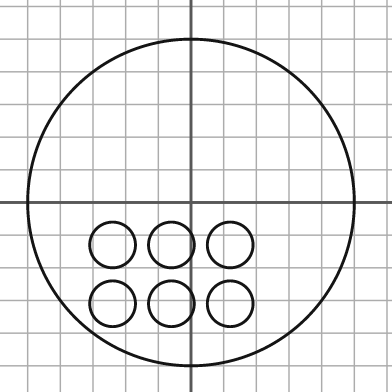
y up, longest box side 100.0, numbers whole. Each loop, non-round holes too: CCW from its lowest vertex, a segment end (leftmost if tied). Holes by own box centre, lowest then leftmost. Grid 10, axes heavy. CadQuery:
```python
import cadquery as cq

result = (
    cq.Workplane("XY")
    .moveTo(0.0, 0.0)
    .circle(50.0)
    .moveTo(-24.0, -31.0)
    .circle(7.0)
    .moveTo(-6.0, -31.0)
    .circle(7.0)
    .moveTo(12.0, -31.0)
    .circle(7.0)
    .moveTo(-24.0, -13.0)
    .circle(7.0)
    .moveTo(-6.0, -13.0)
    .circle(7.0)
    .moveTo(12.0, -13.0)
    .circle(7.0)
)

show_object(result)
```